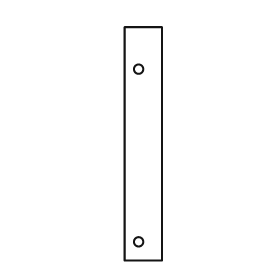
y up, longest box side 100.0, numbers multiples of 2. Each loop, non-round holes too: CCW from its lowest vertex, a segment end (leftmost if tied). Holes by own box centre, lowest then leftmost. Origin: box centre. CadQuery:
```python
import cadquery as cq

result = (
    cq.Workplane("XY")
    .moveTo(-8.0, -50.0)
    .lineTo(8.0, -50.0)
    .lineTo(8.0, 50.0)
    .lineTo(-8.0, 50.0)
    .close()
    .moveTo(-2.0, -42.0)
    .circle(2.0)
    .moveTo(-2.0, 32.0)
    .circle(2.0)
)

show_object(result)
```